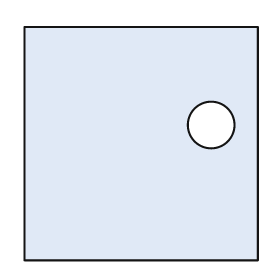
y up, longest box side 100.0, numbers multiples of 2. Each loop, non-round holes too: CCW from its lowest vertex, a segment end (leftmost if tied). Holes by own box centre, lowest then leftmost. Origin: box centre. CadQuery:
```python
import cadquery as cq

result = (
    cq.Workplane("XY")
    .moveTo(-50.0, -50.0)
    .lineTo(50.0, -50.0)
    .lineTo(50.0, 50.0)
    .lineTo(-50.0, 50.0)
    .close()
    .moveTo(30.0, 8.0)
    .circle(10.0)
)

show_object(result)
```